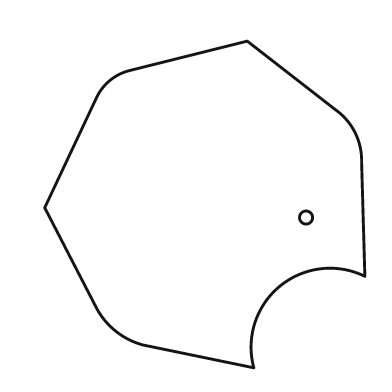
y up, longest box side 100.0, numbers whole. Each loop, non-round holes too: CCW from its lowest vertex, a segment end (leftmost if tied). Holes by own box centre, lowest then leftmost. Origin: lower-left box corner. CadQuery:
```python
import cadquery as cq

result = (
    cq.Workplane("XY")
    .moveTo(64.0, 0.0)
    .threePointArc((72.0, 25.0), (98.0, 28.0))
    .lineTo(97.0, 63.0)
    .threePointArc((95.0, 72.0), (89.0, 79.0))
    .lineTo(62.0, 100.0)
    .lineTo(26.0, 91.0)
    .threePointArc((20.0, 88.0), (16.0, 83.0))
    .lineTo(0.0, 49.0)
    .lineTo(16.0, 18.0)
    .threePointArc((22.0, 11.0), (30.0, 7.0))
    .close()
    .moveTo(80.0, 46.0)
    .circle(2.0)
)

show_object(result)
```